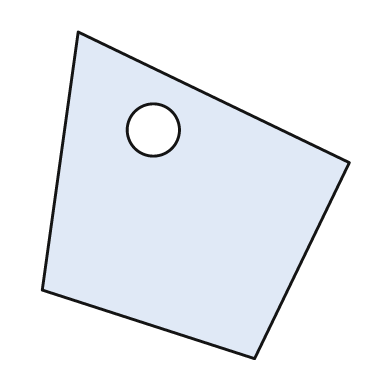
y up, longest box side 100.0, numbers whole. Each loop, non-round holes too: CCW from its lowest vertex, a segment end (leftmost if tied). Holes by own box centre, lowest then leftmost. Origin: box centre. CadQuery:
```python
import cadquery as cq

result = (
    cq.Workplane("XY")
    .moveTo(18.0, -50.0)
    .lineTo(47.0, 10.0)
    .lineTo(-36.0, 50.0)
    .lineTo(-47.0, -29.0)
    .close()
    .moveTo(-13.0, 20.0)
    .circle(8.0)
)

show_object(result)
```